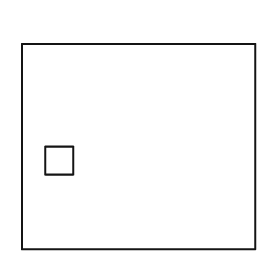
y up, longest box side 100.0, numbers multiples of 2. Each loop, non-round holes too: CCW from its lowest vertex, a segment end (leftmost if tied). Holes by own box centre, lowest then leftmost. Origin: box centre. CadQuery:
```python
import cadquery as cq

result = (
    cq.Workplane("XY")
    .moveTo(-50.0, -44.0)
    .lineTo(50.0, -44.0)
    .lineTo(50.0, 44.0)
    .lineTo(-50.0, 44.0)
    .close()
    .moveTo(-40.0, -12.0)
    .lineTo(-28.0, -12.0)
    .lineTo(-28.0, 0.0)
    .lineTo(-40.0, 0.0)
    .close()
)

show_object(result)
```